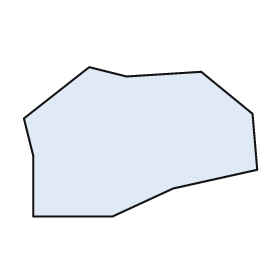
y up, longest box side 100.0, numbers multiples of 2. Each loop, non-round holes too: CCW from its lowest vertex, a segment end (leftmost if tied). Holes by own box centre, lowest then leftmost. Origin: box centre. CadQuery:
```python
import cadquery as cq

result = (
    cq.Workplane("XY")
    .moveTo(-46.0, -32.0)
    .lineTo(-12.0, -32.0)
    .lineTo(14.0, -20.0)
    .lineTo(50.0, -12.0)
    .lineTo(48.0, 12.0)
    .lineTo(26.0, 30.0)
    .lineTo(-6.0, 28.0)
    .lineTo(-22.0, 32.0)
    .lineTo(-50.0, 10.0)
    .lineTo(-46.0, -6.0)
    .close()
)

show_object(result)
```